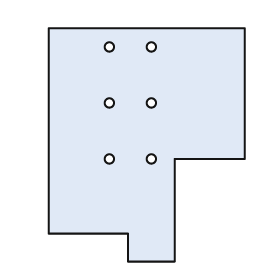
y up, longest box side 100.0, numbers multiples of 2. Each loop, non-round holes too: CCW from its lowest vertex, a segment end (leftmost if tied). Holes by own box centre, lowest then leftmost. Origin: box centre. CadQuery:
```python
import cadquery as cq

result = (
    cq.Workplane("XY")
    .moveTo(-8.0, -50.0)
    .lineTo(12.0, -50.0)
    .lineTo(12.0, -6.0)
    .lineTo(42.0, -6.0)
    .lineTo(42.0, 50.0)
    .lineTo(-42.0, 50.0)
    .lineTo(-42.0, -38.0)
    .lineTo(-8.0, -38.0)
    .close()
    .moveTo(-16.0, -6.0)
    .circle(2.0)
    .moveTo(2.0, -6.0)
    .circle(2.0)
    .moveTo(-16.0, 18.0)
    .circle(2.0)
    .moveTo(2.0, 18.0)
    .circle(2.0)
    .moveTo(-16.0, 42.0)
    .circle(2.0)
    .moveTo(2.0, 42.0)
    .circle(2.0)
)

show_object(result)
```